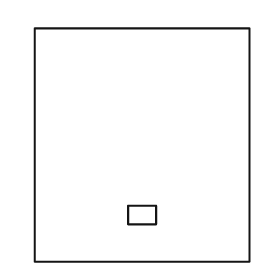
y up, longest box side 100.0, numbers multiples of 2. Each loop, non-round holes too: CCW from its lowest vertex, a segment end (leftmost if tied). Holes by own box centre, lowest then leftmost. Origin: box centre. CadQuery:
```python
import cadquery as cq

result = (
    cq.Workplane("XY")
    .moveTo(-46.0, -50.0)
    .lineTo(46.0, -50.0)
    .lineTo(46.0, 50.0)
    .lineTo(-46.0, 50.0)
    .close()
    .moveTo(-6.0, -34.0)
    .lineTo(6.0, -34.0)
    .lineTo(6.0, -26.0)
    .lineTo(-6.0, -26.0)
    .close()
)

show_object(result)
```